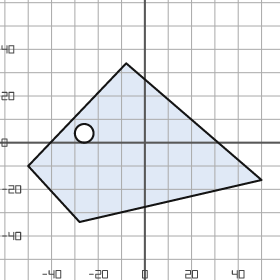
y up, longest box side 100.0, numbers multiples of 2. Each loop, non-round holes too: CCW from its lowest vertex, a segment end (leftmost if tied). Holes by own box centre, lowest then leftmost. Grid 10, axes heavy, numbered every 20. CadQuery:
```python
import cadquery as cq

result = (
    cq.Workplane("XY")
    .moveTo(-28.0, -34.0)
    .lineTo(50.0, -16.0)
    .lineTo(-8.0, 34.0)
    .lineTo(-50.0, -10.0)
    .close()
    .moveTo(-26.0, 4.0)
    .circle(4.0)
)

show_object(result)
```